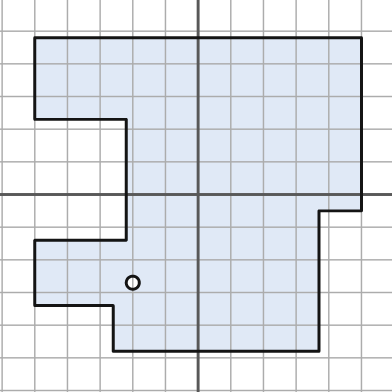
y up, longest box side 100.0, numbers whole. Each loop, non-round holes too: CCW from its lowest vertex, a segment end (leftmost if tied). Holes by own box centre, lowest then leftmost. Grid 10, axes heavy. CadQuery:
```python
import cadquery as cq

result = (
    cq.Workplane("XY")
    .moveTo(-26.0, -48.0)
    .lineTo(37.0, -48.0)
    .lineTo(37.0, -5.0)
    .lineTo(50.0, -5.0)
    .lineTo(50.0, 48.0)
    .lineTo(-50.0, 48.0)
    .lineTo(-50.0, 23.0)
    .lineTo(-22.0, 23.0)
    .lineTo(-22.0, -14.0)
    .lineTo(-50.0, -14.0)
    .lineTo(-50.0, -34.0)
    .lineTo(-26.0, -34.0)
    .close()
    .moveTo(-20.0, -27.0)
    .circle(2.0)
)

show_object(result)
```